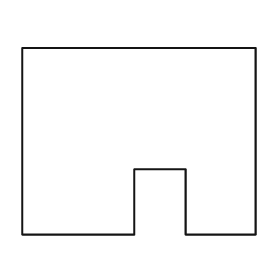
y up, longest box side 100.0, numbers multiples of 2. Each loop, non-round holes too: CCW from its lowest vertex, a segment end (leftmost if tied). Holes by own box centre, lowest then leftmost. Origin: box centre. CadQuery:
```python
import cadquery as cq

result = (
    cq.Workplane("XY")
    .moveTo(-50.0, -40.0)
    .lineTo(-2.0, -40.0)
    .lineTo(-2.0, -12.0)
    .lineTo(20.0, -12.0)
    .lineTo(20.0, -40.0)
    .lineTo(50.0, -40.0)
    .lineTo(50.0, 40.0)
    .lineTo(-50.0, 40.0)
    .close()
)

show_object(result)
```